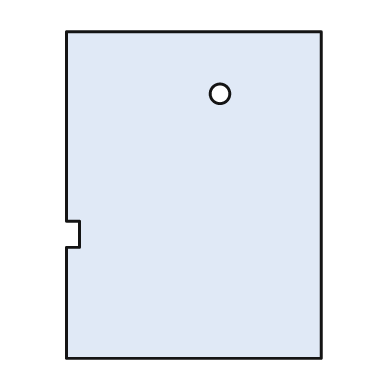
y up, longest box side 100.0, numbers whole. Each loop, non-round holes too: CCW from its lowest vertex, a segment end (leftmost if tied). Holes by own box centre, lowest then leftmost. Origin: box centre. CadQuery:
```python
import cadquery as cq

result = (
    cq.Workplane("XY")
    .moveTo(-39.0, -50.0)
    .lineTo(39.0, -50.0)
    .lineTo(39.0, 50.0)
    .lineTo(-39.0, 50.0)
    .lineTo(-39.0, -8.0)
    .lineTo(-35.0, -8.0)
    .lineTo(-35.0, -16.0)
    .lineTo(-39.0, -16.0)
    .close()
    .moveTo(8.0, 31.0)
    .circle(3.0)
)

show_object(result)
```